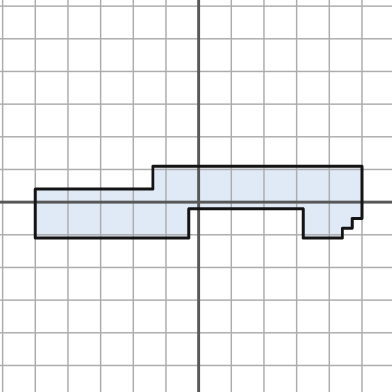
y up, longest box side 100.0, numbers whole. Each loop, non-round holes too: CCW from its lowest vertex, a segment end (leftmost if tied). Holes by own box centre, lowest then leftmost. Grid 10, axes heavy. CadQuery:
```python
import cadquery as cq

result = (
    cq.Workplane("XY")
    .moveTo(-50.0, -11.0)
    .lineTo(-3.0, -11.0)
    .lineTo(-3.0, -2.0)
    .lineTo(32.0, -2.0)
    .lineTo(32.0, -11.0)
    .lineTo(44.0, -11.0)
    .lineTo(44.0, -8.0)
    .lineTo(47.0, -8.0)
    .lineTo(47.0, -5.0)
    .lineTo(50.0, -5.0)
    .lineTo(50.0, 11.0)
    .lineTo(-14.0, 11.0)
    .lineTo(-14.0, 4.0)
    .lineTo(-50.0, 4.0)
    .close()
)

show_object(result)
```